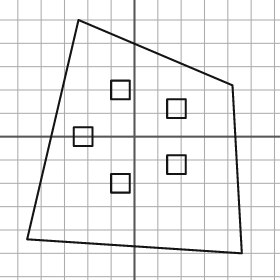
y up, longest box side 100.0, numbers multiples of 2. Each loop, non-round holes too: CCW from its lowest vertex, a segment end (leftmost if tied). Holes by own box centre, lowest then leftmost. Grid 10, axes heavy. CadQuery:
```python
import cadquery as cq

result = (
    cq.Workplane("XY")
    .moveTo(46.0, -50.0)
    .lineTo(42.0, 22.0)
    .lineTo(-24.0, 50.0)
    .lineTo(-46.0, -44.0)
    .close()
    .moveTo(-10.0, -24.0)
    .lineTo(-2.0, -24.0)
    .lineTo(-2.0, -16.0)
    .lineTo(-10.0, -16.0)
    .close()
    .moveTo(14.0, -16.0)
    .lineTo(22.0, -16.0)
    .lineTo(22.0, -8.0)
    .lineTo(14.0, -8.0)
    .close()
    .moveTo(-26.0, -4.0)
    .lineTo(-18.0, -4.0)
    .lineTo(-18.0, 4.0)
    .lineTo(-26.0, 4.0)
    .close()
    .moveTo(14.0, 8.0)
    .lineTo(22.0, 8.0)
    .lineTo(22.0, 16.0)
    .lineTo(14.0, 16.0)
    .close()
    .moveTo(-10.0, 16.0)
    .lineTo(-2.0, 16.0)
    .lineTo(-2.0, 24.0)
    .lineTo(-10.0, 24.0)
    .close()
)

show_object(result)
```